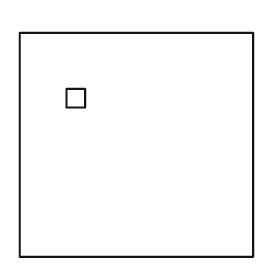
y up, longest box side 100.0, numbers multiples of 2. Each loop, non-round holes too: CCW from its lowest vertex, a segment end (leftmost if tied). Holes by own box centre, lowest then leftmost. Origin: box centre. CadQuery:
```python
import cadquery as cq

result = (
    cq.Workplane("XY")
    .moveTo(-50.0, -48.0)
    .lineTo(50.0, -48.0)
    .lineTo(50.0, 48.0)
    .lineTo(-50.0, 48.0)
    .close()
    .moveTo(-30.0, 16.0)
    .lineTo(-22.0, 16.0)
    .lineTo(-22.0, 24.0)
    .lineTo(-30.0, 24.0)
    .close()
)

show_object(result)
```